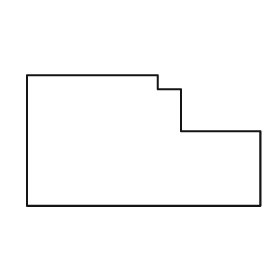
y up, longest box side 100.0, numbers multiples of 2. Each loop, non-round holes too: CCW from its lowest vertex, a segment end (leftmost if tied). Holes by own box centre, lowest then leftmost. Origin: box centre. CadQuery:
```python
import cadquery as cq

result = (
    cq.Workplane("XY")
    .moveTo(-50.0, -28.0)
    .lineTo(50.0, -28.0)
    .lineTo(50.0, 4.0)
    .lineTo(16.0, 4.0)
    .lineTo(16.0, 22.0)
    .lineTo(6.0, 22.0)
    .lineTo(6.0, 28.0)
    .lineTo(-50.0, 28.0)
    .close()
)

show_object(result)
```